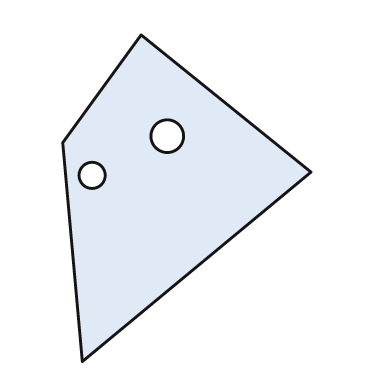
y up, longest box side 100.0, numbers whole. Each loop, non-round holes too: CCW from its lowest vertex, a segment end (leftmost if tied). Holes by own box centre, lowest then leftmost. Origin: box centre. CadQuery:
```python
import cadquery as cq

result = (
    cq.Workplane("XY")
    .moveTo(-32.0, -50.0)
    .lineTo(38.0, 8.0)
    .lineTo(-14.0, 50.0)
    .lineTo(-38.0, 17.0)
    .close()
    .moveTo(-29.0, 7.0)
    .circle(4.0)
    .moveTo(-6.0, 19.0)
    .circle(5.0)
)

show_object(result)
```